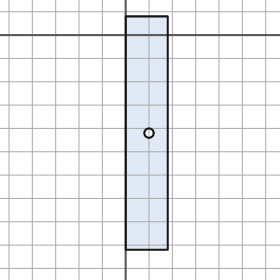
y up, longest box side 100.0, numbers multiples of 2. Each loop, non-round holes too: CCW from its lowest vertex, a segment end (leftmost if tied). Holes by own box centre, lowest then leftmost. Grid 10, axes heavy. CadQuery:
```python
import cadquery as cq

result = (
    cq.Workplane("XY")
    .moveTo(0.0, -92.0)
    .lineTo(18.0, -92.0)
    .lineTo(18.0, 8.0)
    .lineTo(0.0, 8.0)
    .close()
    .moveTo(10.0, -42.0)
    .circle(2.0)
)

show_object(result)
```